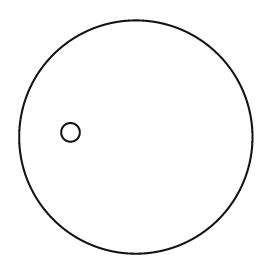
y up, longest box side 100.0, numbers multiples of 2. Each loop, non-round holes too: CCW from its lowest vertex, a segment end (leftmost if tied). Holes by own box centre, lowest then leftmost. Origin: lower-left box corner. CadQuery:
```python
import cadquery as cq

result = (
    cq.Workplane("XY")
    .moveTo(50.0, 50.0)
    .circle(50.0)
    .moveTo(22.0, 52.0)
    .circle(4.0)
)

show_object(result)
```